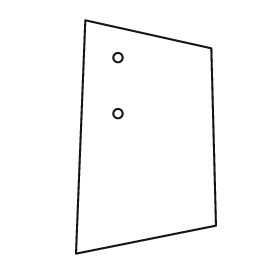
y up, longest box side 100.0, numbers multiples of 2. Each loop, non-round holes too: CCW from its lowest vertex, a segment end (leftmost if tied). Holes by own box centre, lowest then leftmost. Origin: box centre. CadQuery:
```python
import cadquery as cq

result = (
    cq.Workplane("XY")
    .moveTo(-30.0, -50.0)
    .lineTo(30.0, -38.0)
    .lineTo(28.0, 38.0)
    .lineTo(-26.0, 50.0)
    .close()
    .moveTo(-12.0, 10.0)
    .circle(2.0)
    .moveTo(-12.0, 34.0)
    .circle(2.0)
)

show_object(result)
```